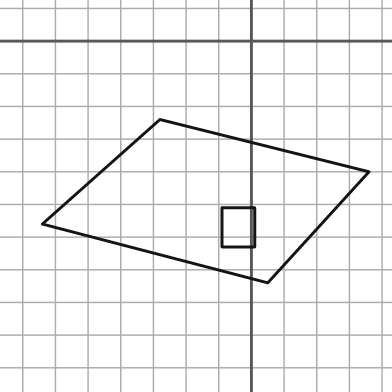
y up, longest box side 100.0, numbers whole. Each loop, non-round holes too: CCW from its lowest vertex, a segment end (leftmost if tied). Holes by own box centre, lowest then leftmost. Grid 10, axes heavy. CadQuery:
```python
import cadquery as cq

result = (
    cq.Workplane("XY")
    .moveTo(5.0, -74.0)
    .lineTo(36.0, -40.0)
    .lineTo(-28.0, -24.0)
    .lineTo(-64.0, -56.0)
    .close()
    .moveTo(-9.0, -63.0)
    .lineTo(1.0, -63.0)
    .lineTo(1.0, -51.0)
    .lineTo(-9.0, -51.0)
    .close()
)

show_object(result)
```